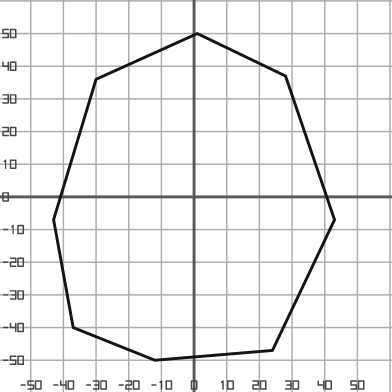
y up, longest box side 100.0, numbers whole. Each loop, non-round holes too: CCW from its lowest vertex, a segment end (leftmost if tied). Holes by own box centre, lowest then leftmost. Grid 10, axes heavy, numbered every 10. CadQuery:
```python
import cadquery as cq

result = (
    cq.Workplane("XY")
    .moveTo(-12.0, -50.0)
    .lineTo(24.0, -47.0)
    .lineTo(43.0, -7.0)
    .lineTo(28.0, 37.0)
    .lineTo(1.0, 50.0)
    .lineTo(-30.0, 36.0)
    .lineTo(-43.0, -7.0)
    .lineTo(-37.0, -40.0)
    .close()
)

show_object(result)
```